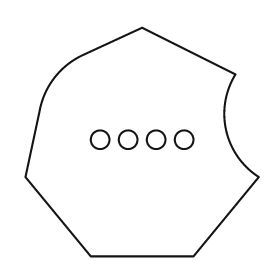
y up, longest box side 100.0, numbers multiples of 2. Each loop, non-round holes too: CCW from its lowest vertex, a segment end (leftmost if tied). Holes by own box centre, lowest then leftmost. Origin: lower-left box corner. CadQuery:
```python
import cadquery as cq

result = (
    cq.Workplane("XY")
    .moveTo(28.0, 0.0)
    .lineTo(72.0, 0.0)
    .lineTo(100.0, 34.0)
    .threePointArc((86.0, 54.0), (90.0, 78.0))
    .lineTo(50.0, 98.0)
    .lineTo(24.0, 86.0)
    .threePointArc((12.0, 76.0), (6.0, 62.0))
    .lineTo(0.0, 34.0)
    .close()
    .moveTo(32.0, 50.0)
    .circle(4.0)
    .moveTo(44.0, 50.0)
    .circle(4.0)
    .moveTo(56.0, 50.0)
    .circle(4.0)
    .moveTo(68.0, 50.0)
    .circle(4.0)
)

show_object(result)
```